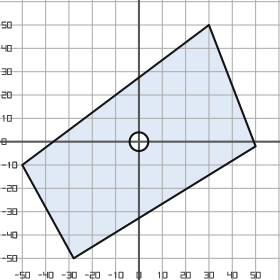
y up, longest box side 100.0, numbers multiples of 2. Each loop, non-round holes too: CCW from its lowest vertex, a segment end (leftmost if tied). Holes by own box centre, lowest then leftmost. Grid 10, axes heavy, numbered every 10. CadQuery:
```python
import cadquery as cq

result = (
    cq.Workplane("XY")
    .moveTo(-28.0, -50.0)
    .lineTo(50.0, -2.0)
    .lineTo(30.0, 50.0)
    .lineTo(-50.0, -10.0)
    .close()
    .moveTo(0.0, 0.0)
    .circle(4.0)
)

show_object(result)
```